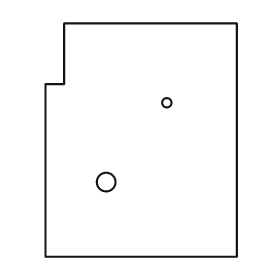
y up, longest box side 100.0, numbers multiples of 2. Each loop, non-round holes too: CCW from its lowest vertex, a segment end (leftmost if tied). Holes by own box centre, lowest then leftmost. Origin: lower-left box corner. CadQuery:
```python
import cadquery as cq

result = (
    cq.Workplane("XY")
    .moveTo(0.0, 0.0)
    .lineTo(82.0, 0.0)
    .lineTo(82.0, 100.0)
    .lineTo(8.0, 100.0)
    .lineTo(8.0, 74.0)
    .lineTo(0.0, 74.0)
    .close()
    .moveTo(26.0, 32.0)
    .circle(4.0)
    .moveTo(52.0, 66.0)
    .circle(2.0)
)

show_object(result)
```